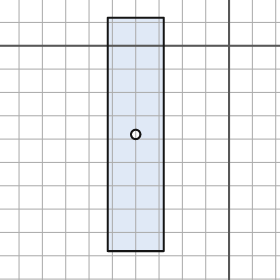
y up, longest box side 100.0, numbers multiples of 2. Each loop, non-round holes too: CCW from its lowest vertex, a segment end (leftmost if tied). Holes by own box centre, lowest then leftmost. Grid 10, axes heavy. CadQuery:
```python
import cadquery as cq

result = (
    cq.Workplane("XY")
    .moveTo(-52.0, -88.0)
    .lineTo(-28.0, -88.0)
    .lineTo(-28.0, 12.0)
    .lineTo(-52.0, 12.0)
    .close()
    .moveTo(-40.0, -38.0)
    .circle(2.0)
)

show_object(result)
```